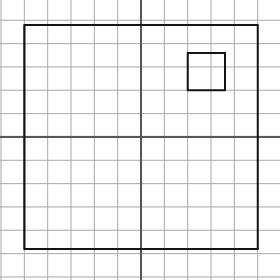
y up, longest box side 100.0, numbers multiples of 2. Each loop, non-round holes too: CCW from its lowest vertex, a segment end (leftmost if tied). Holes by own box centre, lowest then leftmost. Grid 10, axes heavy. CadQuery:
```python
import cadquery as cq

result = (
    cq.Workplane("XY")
    .moveTo(-50.0, -48.0)
    .lineTo(50.0, -48.0)
    .lineTo(50.0, 48.0)
    .lineTo(-50.0, 48.0)
    .close()
    .moveTo(20.0, 20.0)
    .lineTo(36.0, 20.0)
    .lineTo(36.0, 36.0)
    .lineTo(20.0, 36.0)
    .close()
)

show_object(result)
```